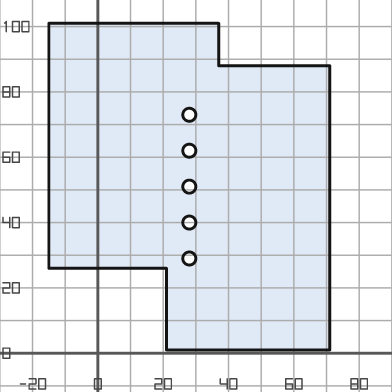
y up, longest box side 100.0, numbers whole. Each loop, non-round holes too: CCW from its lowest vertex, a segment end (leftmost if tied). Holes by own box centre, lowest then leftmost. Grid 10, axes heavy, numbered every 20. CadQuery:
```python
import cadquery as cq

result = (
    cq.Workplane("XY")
    .moveTo(21.0, 1.0)
    .lineTo(71.0, 1.0)
    .lineTo(71.0, 88.0)
    .lineTo(37.0, 88.0)
    .lineTo(37.0, 101.0)
    .lineTo(-15.0, 101.0)
    .lineTo(-15.0, 26.0)
    .lineTo(21.0, 26.0)
    .close()
    .moveTo(28.0, 29.0)
    .circle(2.0)
    .moveTo(28.0, 40.0)
    .circle(2.0)
    .moveTo(28.0, 51.0)
    .circle(2.0)
    .moveTo(28.0, 62.0)
    .circle(2.0)
    .moveTo(28.0, 73.0)
    .circle(2.0)
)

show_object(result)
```